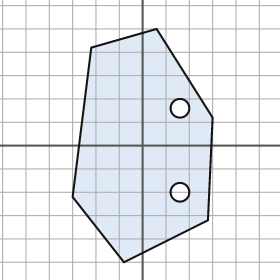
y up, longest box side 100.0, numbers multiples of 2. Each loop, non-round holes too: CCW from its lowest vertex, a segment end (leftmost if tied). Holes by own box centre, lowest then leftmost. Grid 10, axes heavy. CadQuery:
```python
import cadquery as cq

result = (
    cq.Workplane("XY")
    .moveTo(-8.0, -50.0)
    .lineTo(28.0, -32.0)
    .lineTo(30.0, 12.0)
    .lineTo(6.0, 50.0)
    .lineTo(-22.0, 42.0)
    .lineTo(-30.0, -22.0)
    .close()
    .moveTo(16.0, -20.0)
    .circle(4.0)
    .moveTo(16.0, 16.0)
    .circle(4.0)
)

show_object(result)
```